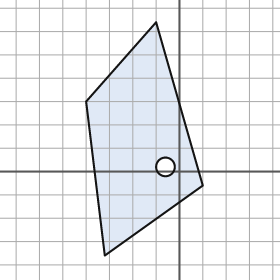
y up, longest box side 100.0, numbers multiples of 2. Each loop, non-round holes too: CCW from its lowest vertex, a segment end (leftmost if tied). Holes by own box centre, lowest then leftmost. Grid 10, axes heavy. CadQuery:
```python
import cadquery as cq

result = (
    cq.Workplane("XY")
    .moveTo(-32.0, -36.0)
    .lineTo(10.0, -6.0)
    .lineTo(-10.0, 64.0)
    .lineTo(-40.0, 30.0)
    .close()
    .moveTo(-6.0, 2.0)
    .circle(4.0)
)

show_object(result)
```